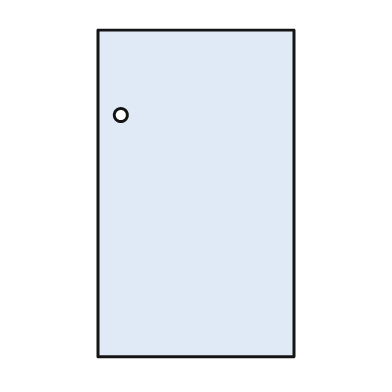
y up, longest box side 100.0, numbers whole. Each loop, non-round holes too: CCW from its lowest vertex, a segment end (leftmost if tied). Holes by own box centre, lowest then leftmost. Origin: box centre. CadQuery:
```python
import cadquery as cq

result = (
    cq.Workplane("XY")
    .moveTo(-30.0, -50.0)
    .lineTo(30.0, -50.0)
    .lineTo(30.0, 50.0)
    .lineTo(-30.0, 50.0)
    .close()
    .moveTo(-23.0, 24.0)
    .circle(2.0)
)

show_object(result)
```